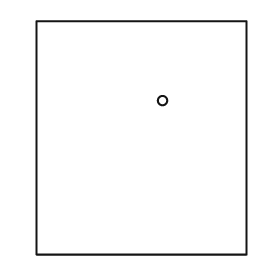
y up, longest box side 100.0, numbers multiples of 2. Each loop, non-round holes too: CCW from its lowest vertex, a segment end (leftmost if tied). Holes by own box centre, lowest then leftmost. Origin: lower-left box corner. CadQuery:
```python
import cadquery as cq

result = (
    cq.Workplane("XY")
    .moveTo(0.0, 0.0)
    .lineTo(90.0, 0.0)
    .lineTo(90.0, 100.0)
    .lineTo(0.0, 100.0)
    .close()
    .moveTo(54.0, 66.0)
    .circle(2.0)
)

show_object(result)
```